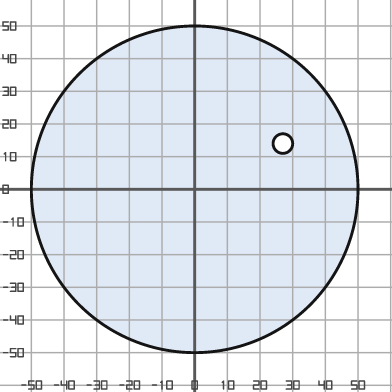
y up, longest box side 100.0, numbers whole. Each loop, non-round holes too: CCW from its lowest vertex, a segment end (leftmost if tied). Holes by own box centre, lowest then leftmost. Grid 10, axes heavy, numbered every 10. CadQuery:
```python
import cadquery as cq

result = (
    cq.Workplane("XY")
    .moveTo(0.0, 0.0)
    .circle(50.0)
    .moveTo(27.0, 14.0)
    .circle(3.0)
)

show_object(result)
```